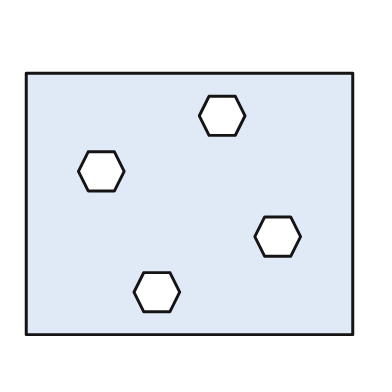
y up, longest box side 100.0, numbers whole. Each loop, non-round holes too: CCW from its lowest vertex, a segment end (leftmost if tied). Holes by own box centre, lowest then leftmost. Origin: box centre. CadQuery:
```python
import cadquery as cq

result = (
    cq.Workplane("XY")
    .moveTo(-50.0, -40.0)
    .lineTo(50.0, -40.0)
    .lineTo(50.0, 40.0)
    .lineTo(-50.0, 40.0)
    .close()
    .moveTo(-14.0, -33.0)
    .lineTo(-6.0, -33.0)
    .lineTo(-3.0, -27.0)
    .lineTo(-6.0, -21.0)
    .lineTo(-14.0, -21.0)
    .lineTo(-17.0, -27.0)
    .close()
    .moveTo(23.0, -16.0)
    .lineTo(31.0, -16.0)
    .lineTo(34.0, -10.0)
    .lineTo(31.0, -4.0)
    .lineTo(23.0, -4.0)
    .lineTo(20.0, -10.0)
    .close()
    .moveTo(-31.0, 4.0)
    .lineTo(-23.0, 4.0)
    .lineTo(-20.0, 10.0)
    .lineTo(-23.0, 16.0)
    .lineTo(-31.0, 16.0)
    .lineTo(-34.0, 10.0)
    .close()
    .moveTo(6.0, 21.0)
    .lineTo(14.0, 21.0)
    .lineTo(17.0, 27.0)
    .lineTo(14.0, 33.0)
    .lineTo(6.0, 33.0)
    .lineTo(3.0, 27.0)
    .close()
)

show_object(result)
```